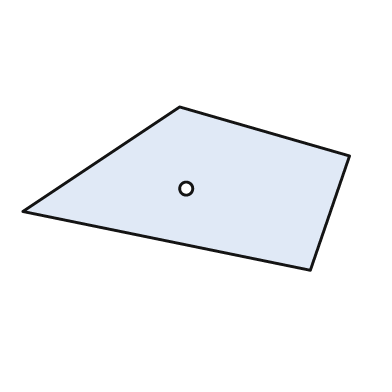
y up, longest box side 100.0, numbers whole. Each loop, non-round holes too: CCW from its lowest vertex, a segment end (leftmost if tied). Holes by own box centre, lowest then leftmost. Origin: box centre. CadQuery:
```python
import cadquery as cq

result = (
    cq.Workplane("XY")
    .moveTo(38.0, -25.0)
    .lineTo(50.0, 10.0)
    .lineTo(-2.0, 25.0)
    .lineTo(-50.0, -7.0)
    .close()
    .moveTo(0.0, 0.0)
    .circle(2.0)
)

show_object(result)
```